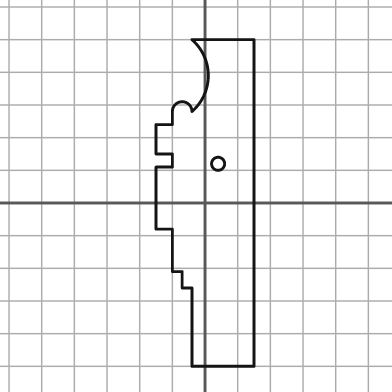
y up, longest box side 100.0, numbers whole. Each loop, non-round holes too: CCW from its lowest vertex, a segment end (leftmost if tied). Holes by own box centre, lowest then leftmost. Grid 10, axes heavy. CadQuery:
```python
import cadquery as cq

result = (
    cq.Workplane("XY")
    .moveTo(-4.0, -50.0)
    .lineTo(15.0, -50.0)
    .lineTo(15.0, 50.0)
    .lineTo(-4.0, 50.0)
    .threePointArc((1.0, 39.0), (-4.0, 28.0))
    .threePointArc((-7.0, 31.0), (-10.0, 28.0))
    .lineTo(-10.0, 24.0)
    .lineTo(-15.0, 24.0)
    .lineTo(-15.0, 15.0)
    .lineTo(-10.0, 15.0)
    .lineTo(-10.0, 11.0)
    .lineTo(-15.0, 11.0)
    .lineTo(-15.0, -8.0)
    .lineTo(-10.0, -8.0)
    .lineTo(-10.0, -21.0)
    .lineTo(-7.0, -21.0)
    .lineTo(-7.0, -26.0)
    .lineTo(-4.0, -26.0)
    .close()
    .moveTo(4.0, 12.0)
    .circle(2.0)
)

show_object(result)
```